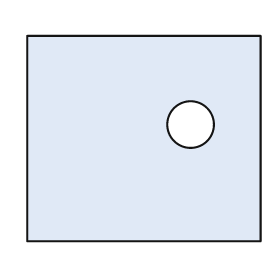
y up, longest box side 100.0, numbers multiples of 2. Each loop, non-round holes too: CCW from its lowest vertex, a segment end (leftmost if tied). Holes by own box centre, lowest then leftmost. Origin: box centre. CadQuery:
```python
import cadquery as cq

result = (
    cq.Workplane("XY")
    .moveTo(-50.0, -44.0)
    .lineTo(50.0, -44.0)
    .lineTo(50.0, 44.0)
    .lineTo(-50.0, 44.0)
    .close()
    .moveTo(20.0, 6.0)
    .circle(10.0)
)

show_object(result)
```